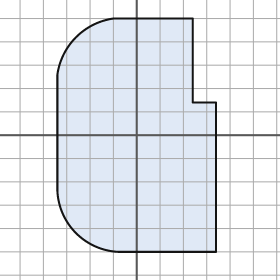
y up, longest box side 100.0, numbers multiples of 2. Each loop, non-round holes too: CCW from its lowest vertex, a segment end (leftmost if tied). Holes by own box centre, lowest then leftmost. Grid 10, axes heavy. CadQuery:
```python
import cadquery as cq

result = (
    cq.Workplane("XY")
    .moveTo(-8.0, -50.0)
    .lineTo(34.0, -50.0)
    .lineTo(34.0, 14.0)
    .lineTo(24.0, 14.0)
    .lineTo(24.0, 50.0)
    .lineTo(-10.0, 50.0)
    .threePointArc((-26.0, 42.0), (-34.0, 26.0))
    .lineTo(-34.0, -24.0)
    .threePointArc((-26.0, -42.0), (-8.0, -50.0))
    .close()
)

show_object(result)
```